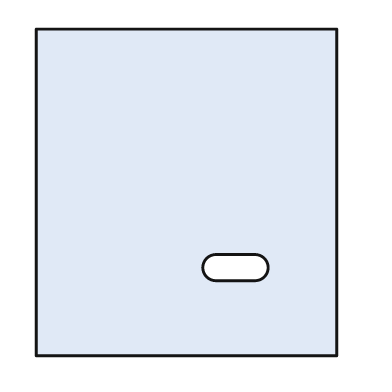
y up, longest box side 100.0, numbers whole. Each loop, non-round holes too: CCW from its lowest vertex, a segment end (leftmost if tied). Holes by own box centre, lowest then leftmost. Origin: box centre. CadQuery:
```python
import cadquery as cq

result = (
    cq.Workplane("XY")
    .moveTo(-46.0, -50.0)
    .lineTo(46.0, -50.0)
    .lineTo(46.0, 50.0)
    .lineTo(-46.0, 50.0)
    .close()
    .moveTo(9.0, -27.0)
    .lineTo(21.0, -27.0)
    .threePointArc((25.0, -23.0), (21.0, -19.0))
    .lineTo(9.0, -19.0)
    .threePointArc((5.0, -23.0), (9.0, -27.0))
    .close()
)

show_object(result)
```